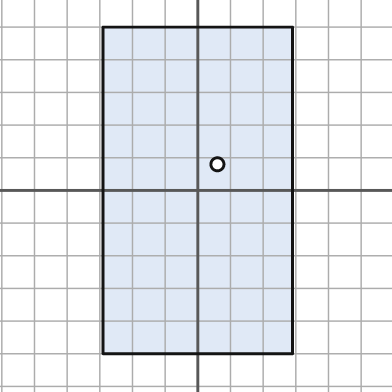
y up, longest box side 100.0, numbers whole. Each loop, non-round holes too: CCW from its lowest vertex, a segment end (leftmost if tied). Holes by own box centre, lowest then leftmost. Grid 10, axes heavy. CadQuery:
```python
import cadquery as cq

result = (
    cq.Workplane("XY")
    .moveTo(-29.0, -50.0)
    .lineTo(29.0, -50.0)
    .lineTo(29.0, 50.0)
    .lineTo(-29.0, 50.0)
    .close()
    .moveTo(6.0, 8.0)
    .circle(2.0)
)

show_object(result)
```